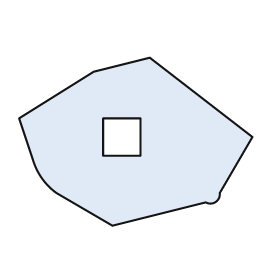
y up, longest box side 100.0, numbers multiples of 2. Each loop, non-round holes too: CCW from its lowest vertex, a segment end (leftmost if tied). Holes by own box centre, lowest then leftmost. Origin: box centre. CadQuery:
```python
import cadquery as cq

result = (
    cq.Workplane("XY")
    .moveTo(-10.0, -36.0)
    .lineTo(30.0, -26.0)
    .threePointArc((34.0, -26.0), (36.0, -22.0))
    .lineTo(50.0, 2.0)
    .lineTo(6.0, 36.0)
    .lineTo(-18.0, 30.0)
    .lineTo(-50.0, 10.0)
    .lineTo(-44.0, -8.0)
    .threePointArc((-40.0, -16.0), (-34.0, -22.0))
    .close()
    .moveTo(-14.0, -6.0)
    .lineTo(2.0, -6.0)
    .lineTo(2.0, 10.0)
    .lineTo(-14.0, 10.0)
    .close()
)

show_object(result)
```